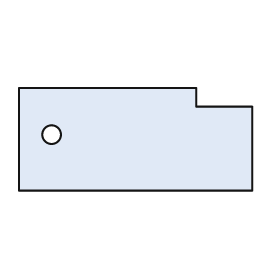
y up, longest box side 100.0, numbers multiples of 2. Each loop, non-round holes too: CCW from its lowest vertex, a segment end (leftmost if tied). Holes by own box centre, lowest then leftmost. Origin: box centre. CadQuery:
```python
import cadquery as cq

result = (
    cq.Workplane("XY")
    .moveTo(-50.0, -22.0)
    .lineTo(50.0, -22.0)
    .lineTo(50.0, 14.0)
    .lineTo(26.0, 14.0)
    .lineTo(26.0, 22.0)
    .lineTo(-50.0, 22.0)
    .close()
    .moveTo(-36.0, 2.0)
    .circle(4.0)
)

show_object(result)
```